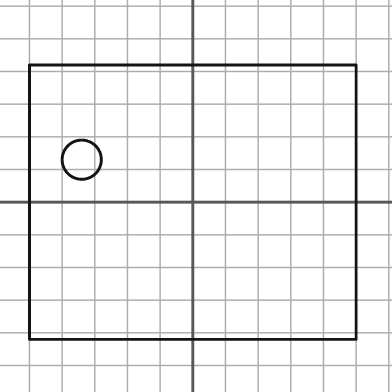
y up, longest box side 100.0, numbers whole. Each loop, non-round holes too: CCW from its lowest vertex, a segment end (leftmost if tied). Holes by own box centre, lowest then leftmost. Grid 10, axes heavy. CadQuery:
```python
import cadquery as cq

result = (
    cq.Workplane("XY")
    .moveTo(-50.0, -42.0)
    .lineTo(50.0, -42.0)
    .lineTo(50.0, 42.0)
    .lineTo(-50.0, 42.0)
    .close()
    .moveTo(-34.0, 13.0)
    .circle(6.0)
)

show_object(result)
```